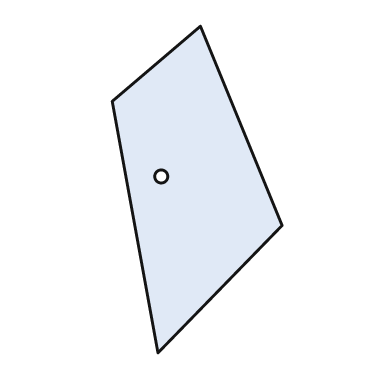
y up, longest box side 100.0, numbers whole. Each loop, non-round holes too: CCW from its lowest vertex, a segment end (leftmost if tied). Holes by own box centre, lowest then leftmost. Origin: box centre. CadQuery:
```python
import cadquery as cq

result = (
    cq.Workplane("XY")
    .moveTo(-12.0, -50.0)
    .lineTo(26.0, -11.0)
    .lineTo(1.0, 50.0)
    .lineTo(-26.0, 27.0)
    .close()
    .moveTo(-11.0, 4.0)
    .circle(2.0)
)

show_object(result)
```